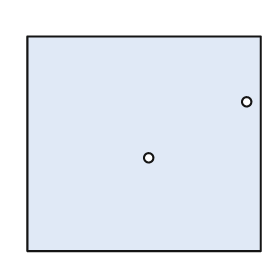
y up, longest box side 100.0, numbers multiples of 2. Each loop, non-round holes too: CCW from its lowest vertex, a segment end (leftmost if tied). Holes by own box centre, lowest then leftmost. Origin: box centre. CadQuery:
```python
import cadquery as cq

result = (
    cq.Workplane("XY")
    .moveTo(-50.0, -46.0)
    .lineTo(50.0, -46.0)
    .lineTo(50.0, 46.0)
    .lineTo(-50.0, 46.0)
    .close()
    .moveTo(2.0, -6.0)
    .circle(2.0)
    .moveTo(44.0, 18.0)
    .circle(2.0)
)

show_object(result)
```